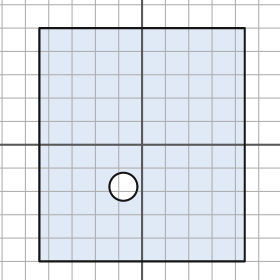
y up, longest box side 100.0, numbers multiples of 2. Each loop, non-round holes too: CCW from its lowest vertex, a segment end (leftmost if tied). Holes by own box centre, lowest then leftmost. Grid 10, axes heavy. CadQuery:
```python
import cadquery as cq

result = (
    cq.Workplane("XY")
    .moveTo(-44.0, -50.0)
    .lineTo(44.0, -50.0)
    .lineTo(44.0, 50.0)
    .lineTo(-44.0, 50.0)
    .close()
    .moveTo(-8.0, -18.0)
    .circle(6.0)
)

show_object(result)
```